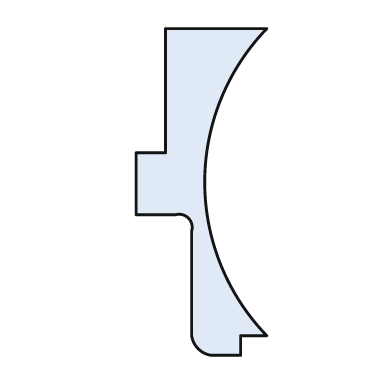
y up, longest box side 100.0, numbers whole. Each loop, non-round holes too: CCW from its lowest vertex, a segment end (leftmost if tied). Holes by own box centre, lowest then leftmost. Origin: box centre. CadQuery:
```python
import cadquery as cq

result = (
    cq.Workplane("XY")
    .moveTo(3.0, -50.0)
    .lineTo(12.0, -50.0)
    .lineTo(12.0, -44.0)
    .lineTo(20.0, -44.0)
    .threePointArc((1.0, 3.0), (20.0, 50.0))
    .lineTo(-11.0, 50.0)
    .lineTo(-11.0, 12.0)
    .lineTo(-20.0, 12.0)
    .lineTo(-20.0, -7.0)
    .lineTo(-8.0, -7.0)
    .threePointArc((-4.0, -8.0), (-3.0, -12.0))
    .lineTo(-3.0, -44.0)
    .threePointArc((-1.0, -48.0), (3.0, -50.0))
    .close()
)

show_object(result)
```